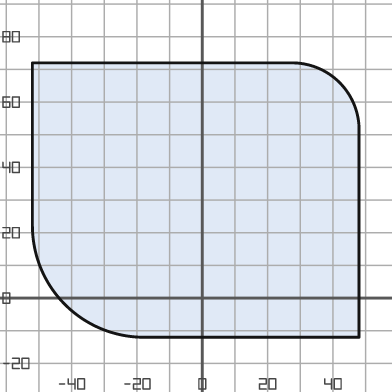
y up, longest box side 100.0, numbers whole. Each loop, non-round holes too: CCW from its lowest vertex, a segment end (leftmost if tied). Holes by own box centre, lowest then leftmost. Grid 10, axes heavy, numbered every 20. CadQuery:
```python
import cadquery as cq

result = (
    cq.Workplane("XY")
    .moveTo(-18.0, -12.0)
    .lineTo(48.0, -12.0)
    .lineTo(48.0, 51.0)
    .threePointArc((42.0, 66.0), (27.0, 72.0))
    .lineTo(-52.0, 72.0)
    .lineTo(-52.0, 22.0)
    .threePointArc((-42.0, -2.0), (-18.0, -12.0))
    .close()
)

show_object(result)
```